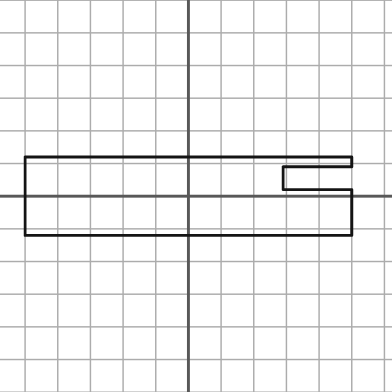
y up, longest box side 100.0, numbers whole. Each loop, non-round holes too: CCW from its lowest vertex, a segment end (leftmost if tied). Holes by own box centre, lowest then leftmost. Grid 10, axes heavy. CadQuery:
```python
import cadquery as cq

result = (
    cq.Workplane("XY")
    .moveTo(-50.0, -12.0)
    .lineTo(50.0, -12.0)
    .lineTo(50.0, 2.0)
    .lineTo(29.0, 2.0)
    .lineTo(29.0, 9.0)
    .lineTo(50.0, 9.0)
    .lineTo(50.0, 12.0)
    .lineTo(-50.0, 12.0)
    .close()
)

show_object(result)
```